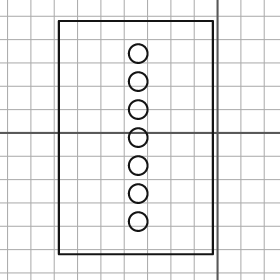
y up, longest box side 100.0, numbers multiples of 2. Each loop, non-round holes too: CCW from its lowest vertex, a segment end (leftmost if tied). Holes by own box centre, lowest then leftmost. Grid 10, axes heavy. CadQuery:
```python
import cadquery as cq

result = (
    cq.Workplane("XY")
    .moveTo(-68.0, -52.0)
    .lineTo(-2.0, -52.0)
    .lineTo(-2.0, 48.0)
    .lineTo(-68.0, 48.0)
    .close()
    .moveTo(-34.0, -38.0)
    .circle(4.0)
    .moveTo(-34.0, -26.0)
    .circle(4.0)
    .moveTo(-34.0, -14.0)
    .circle(4.0)
    .moveTo(-34.0, -2.0)
    .circle(4.0)
    .moveTo(-34.0, 10.0)
    .circle(4.0)
    .moveTo(-34.0, 22.0)
    .circle(4.0)
    .moveTo(-34.0, 34.0)
    .circle(4.0)
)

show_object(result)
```